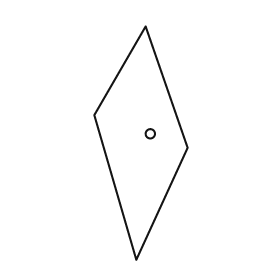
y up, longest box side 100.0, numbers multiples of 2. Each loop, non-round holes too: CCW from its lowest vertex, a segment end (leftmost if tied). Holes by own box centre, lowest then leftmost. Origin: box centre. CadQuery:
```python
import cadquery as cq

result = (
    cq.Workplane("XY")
    .moveTo(-2.0, -50.0)
    .lineTo(20.0, -2.0)
    .lineTo(2.0, 50.0)
    .lineTo(-20.0, 12.0)
    .close()
    .moveTo(4.0, 4.0)
    .circle(2.0)
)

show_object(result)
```